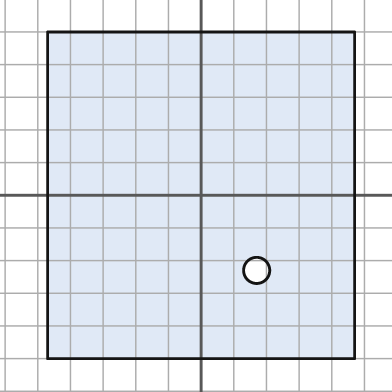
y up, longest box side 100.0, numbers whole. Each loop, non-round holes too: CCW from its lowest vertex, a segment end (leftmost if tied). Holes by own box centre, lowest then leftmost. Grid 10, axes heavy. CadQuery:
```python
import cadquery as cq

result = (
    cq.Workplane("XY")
    .moveTo(-47.0, -50.0)
    .lineTo(47.0, -50.0)
    .lineTo(47.0, 50.0)
    .lineTo(-47.0, 50.0)
    .close()
    .moveTo(17.0, -23.0)
    .circle(4.0)
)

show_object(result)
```